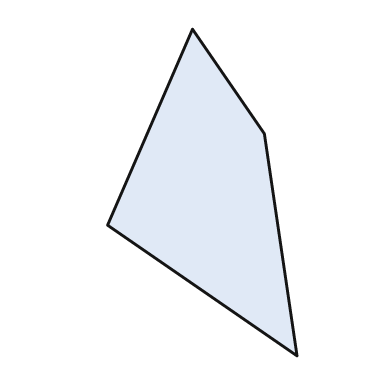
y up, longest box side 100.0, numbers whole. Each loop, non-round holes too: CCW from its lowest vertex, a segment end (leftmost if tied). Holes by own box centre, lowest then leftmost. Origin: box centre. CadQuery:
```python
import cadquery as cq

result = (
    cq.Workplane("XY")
    .moveTo(29.0, -50.0)
    .lineTo(19.0, 18.0)
    .lineTo(-3.0, 50.0)
    .lineTo(-29.0, -10.0)
    .close()
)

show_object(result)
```